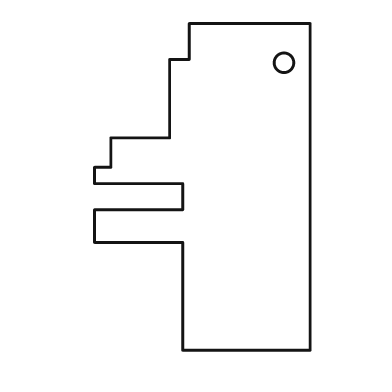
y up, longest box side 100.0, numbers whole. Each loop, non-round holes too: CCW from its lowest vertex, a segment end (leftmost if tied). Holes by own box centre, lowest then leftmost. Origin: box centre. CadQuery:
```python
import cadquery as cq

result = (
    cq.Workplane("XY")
    .moveTo(-6.0, -50.0)
    .lineTo(33.0, -50.0)
    .lineTo(33.0, 50.0)
    .lineTo(-4.0, 50.0)
    .lineTo(-4.0, 39.0)
    .lineTo(-10.0, 39.0)
    .lineTo(-10.0, 15.0)
    .lineTo(-28.0, 15.0)
    .lineTo(-28.0, 6.0)
    .lineTo(-33.0, 6.0)
    .lineTo(-33.0, 1.0)
    .lineTo(-6.0, 1.0)
    .lineTo(-6.0, -7.0)
    .lineTo(-33.0, -7.0)
    .lineTo(-33.0, -17.0)
    .lineTo(-6.0, -17.0)
    .close()
    .moveTo(25.0, 38.0)
    .circle(3.0)
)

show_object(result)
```